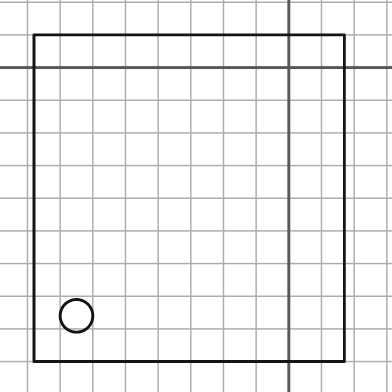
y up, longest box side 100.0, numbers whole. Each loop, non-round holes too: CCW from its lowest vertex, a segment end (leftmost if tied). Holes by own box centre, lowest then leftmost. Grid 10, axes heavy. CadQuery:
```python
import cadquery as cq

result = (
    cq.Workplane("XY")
    .moveTo(-78.0, -90.0)
    .lineTo(17.0, -90.0)
    .lineTo(17.0, 10.0)
    .lineTo(-78.0, 10.0)
    .close()
    .moveTo(-65.0, -76.0)
    .circle(5.0)
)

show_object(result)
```